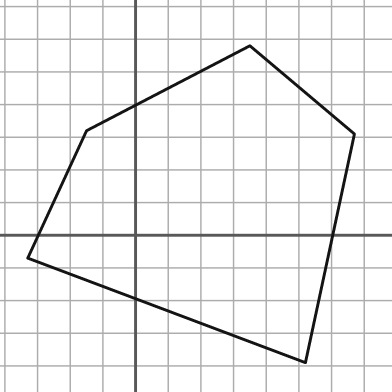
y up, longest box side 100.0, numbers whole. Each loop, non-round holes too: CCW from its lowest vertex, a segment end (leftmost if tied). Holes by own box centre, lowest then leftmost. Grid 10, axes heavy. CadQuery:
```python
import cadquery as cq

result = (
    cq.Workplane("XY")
    .moveTo(52.0, -39.0)
    .lineTo(67.0, 31.0)
    .lineTo(35.0, 58.0)
    .lineTo(-15.0, 32.0)
    .lineTo(-33.0, -7.0)
    .close()
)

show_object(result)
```